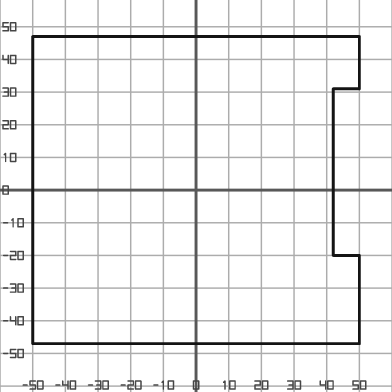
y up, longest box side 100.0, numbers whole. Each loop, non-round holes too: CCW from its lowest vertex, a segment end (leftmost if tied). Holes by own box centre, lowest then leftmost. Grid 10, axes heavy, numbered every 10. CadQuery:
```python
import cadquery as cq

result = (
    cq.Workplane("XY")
    .moveTo(-50.0, -47.0)
    .lineTo(50.0, -47.0)
    .lineTo(50.0, -20.0)
    .lineTo(42.0, -20.0)
    .lineTo(42.0, 31.0)
    .lineTo(50.0, 31.0)
    .lineTo(50.0, 47.0)
    .lineTo(-50.0, 47.0)
    .close()
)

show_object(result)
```